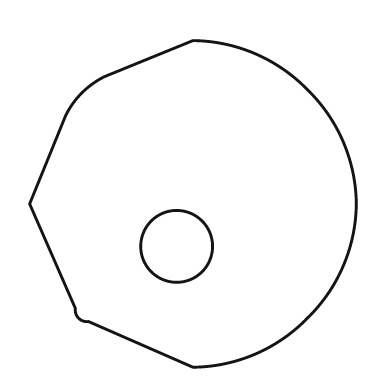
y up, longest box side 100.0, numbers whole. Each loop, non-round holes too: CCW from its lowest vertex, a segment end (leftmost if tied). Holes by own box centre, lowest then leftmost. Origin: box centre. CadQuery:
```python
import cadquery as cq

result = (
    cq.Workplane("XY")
    .moveTo(0.0, -50.0)
    .threePointArc((19.0, -46.0), (35.0, -35.0))
    .threePointArc((46.0, -19.0), (50.0, 0.0))
    .threePointArc((46.0, 19.0), (35.0, 35.0))
    .threePointArc((19.0, 46.0), (0.0, 50.0))
    .lineTo(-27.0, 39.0)
    .threePointArc((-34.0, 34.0), (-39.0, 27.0))
    .lineTo(-50.0, 0.0)
    .lineTo(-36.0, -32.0)
    .threePointArc((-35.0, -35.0), (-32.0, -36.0))
    .close()
    .moveTo(-5.0, -13.0)
    .circle(11.0)
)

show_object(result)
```